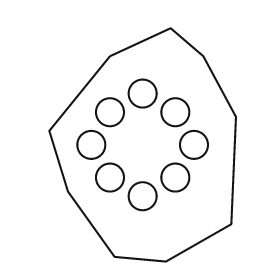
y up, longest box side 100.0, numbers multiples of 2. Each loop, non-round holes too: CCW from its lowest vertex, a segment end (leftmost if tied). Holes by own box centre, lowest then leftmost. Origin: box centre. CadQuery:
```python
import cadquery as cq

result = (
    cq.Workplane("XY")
    .moveTo(10.0, -50.0)
    .lineTo(38.0, -34.0)
    .lineTo(40.0, 12.0)
    .lineTo(26.0, 38.0)
    .lineTo(12.0, 50.0)
    .lineTo(-14.0, 38.0)
    .lineTo(-40.0, 6.0)
    .lineTo(-32.0, -20.0)
    .lineTo(-12.0, -48.0)
    .close()
    .moveTo(0.0, -22.0)
    .circle(6.0)
    .moveTo(-14.0, -14.0)
    .circle(6.0)
    .moveTo(14.0, -14.0)
    .circle(6.0)
    .moveTo(-22.0, 0.0)
    .circle(6.0)
    .moveTo(22.0, 0.0)
    .circle(6.0)
    .moveTo(-14.0, 14.0)
    .circle(6.0)
    .moveTo(14.0, 14.0)
    .circle(6.0)
    .moveTo(0.0, 22.0)
    .circle(6.0)
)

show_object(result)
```